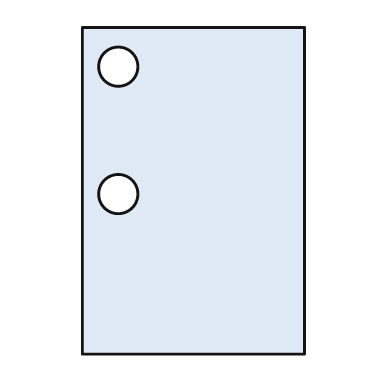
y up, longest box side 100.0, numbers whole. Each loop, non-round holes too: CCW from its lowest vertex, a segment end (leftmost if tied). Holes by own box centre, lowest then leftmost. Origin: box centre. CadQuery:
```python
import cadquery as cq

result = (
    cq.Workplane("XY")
    .moveTo(-34.0, -50.0)
    .lineTo(34.0, -50.0)
    .lineTo(34.0, 50.0)
    .lineTo(-34.0, 50.0)
    .close()
    .moveTo(-23.0, -1.0)
    .circle(6.0)
    .moveTo(-23.0, 38.0)
    .circle(6.0)
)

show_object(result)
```